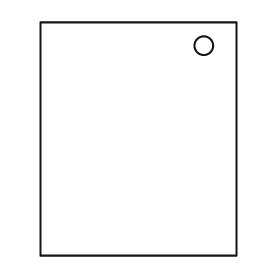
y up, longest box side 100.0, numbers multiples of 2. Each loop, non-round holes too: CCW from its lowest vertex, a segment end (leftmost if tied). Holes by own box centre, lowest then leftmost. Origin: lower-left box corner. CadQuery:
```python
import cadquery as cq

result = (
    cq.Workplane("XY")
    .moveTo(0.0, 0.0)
    .lineTo(84.0, 0.0)
    .lineTo(84.0, 100.0)
    .lineTo(0.0, 100.0)
    .close()
    .moveTo(70.0, 90.0)
    .circle(4.0)
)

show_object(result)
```